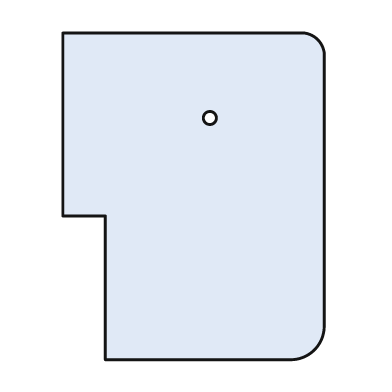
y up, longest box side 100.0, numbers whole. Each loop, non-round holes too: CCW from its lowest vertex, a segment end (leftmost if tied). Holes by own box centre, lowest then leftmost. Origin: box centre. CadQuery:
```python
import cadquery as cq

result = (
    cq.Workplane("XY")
    .moveTo(-27.0, -50.0)
    .lineTo(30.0, -50.0)
    .threePointArc((37.0, -47.0), (40.0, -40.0))
    .lineTo(40.0, 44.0)
    .threePointArc((38.0, 48.0), (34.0, 50.0))
    .lineTo(-40.0, 50.0)
    .lineTo(-40.0, -6.0)
    .lineTo(-27.0, -6.0)
    .close()
    .moveTo(5.0, 24.0)
    .circle(2.0)
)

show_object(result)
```